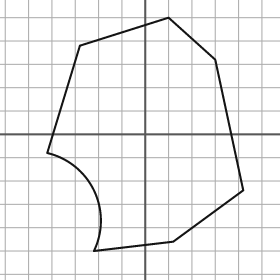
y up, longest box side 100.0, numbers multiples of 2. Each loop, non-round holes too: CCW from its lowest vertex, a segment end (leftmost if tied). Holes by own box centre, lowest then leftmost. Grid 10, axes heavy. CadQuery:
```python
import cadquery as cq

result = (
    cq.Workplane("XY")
    .moveTo(-22.0, -50.0)
    .lineTo(12.0, -46.0)
    .lineTo(42.0, -24.0)
    .lineTo(30.0, 32.0)
    .lineTo(10.0, 50.0)
    .lineTo(-28.0, 38.0)
    .lineTo(-42.0, -8.0)
    .threePointArc((-22.0, -24.0), (-22.0, -50.0))
    .close()
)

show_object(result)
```